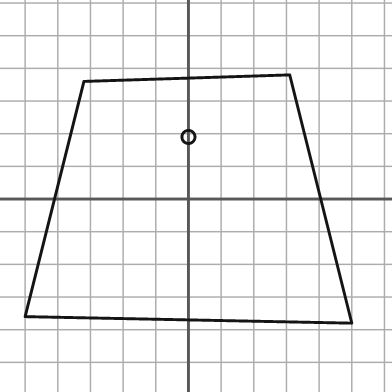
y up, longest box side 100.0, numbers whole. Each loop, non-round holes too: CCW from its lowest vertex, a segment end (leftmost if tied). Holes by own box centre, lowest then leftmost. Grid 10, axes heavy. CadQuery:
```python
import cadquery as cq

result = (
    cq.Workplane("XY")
    .moveTo(50.0, -38.0)
    .lineTo(31.0, 38.0)
    .lineTo(-32.0, 36.0)
    .lineTo(-50.0, -36.0)
    .close()
    .moveTo(0.0, 19.0)
    .circle(2.0)
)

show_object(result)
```